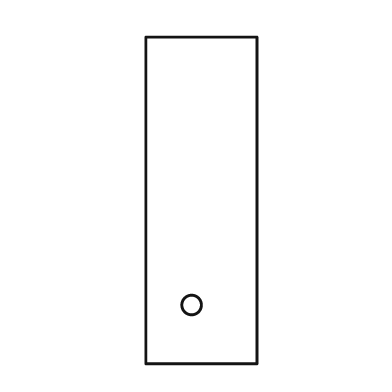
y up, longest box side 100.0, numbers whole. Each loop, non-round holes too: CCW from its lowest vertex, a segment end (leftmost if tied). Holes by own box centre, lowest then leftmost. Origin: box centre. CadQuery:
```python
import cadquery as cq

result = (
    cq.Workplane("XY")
    .moveTo(-17.0, -50.0)
    .lineTo(17.0, -50.0)
    .lineTo(17.0, 50.0)
    .lineTo(-17.0, 50.0)
    .close()
    .moveTo(-3.0, -32.0)
    .circle(3.0)
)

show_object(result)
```